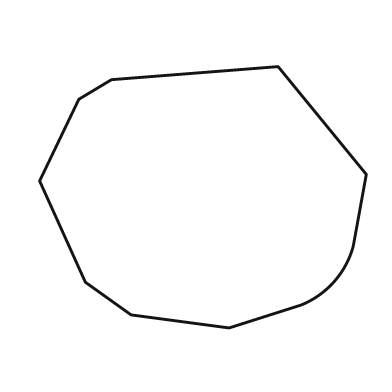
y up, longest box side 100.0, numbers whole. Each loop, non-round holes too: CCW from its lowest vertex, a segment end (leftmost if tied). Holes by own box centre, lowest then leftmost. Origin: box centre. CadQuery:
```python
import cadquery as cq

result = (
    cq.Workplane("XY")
    .moveTo(8.0, -40.0)
    .lineTo(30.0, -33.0)
    .threePointArc((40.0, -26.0), (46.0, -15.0))
    .lineTo(50.0, 7.0)
    .lineTo(23.0, 40.0)
    .lineTo(-28.0, 36.0)
    .lineTo(-38.0, 30.0)
    .lineTo(-50.0, 5.0)
    .lineTo(-36.0, -26.0)
    .lineTo(-22.0, -36.0)
    .close()
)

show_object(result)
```